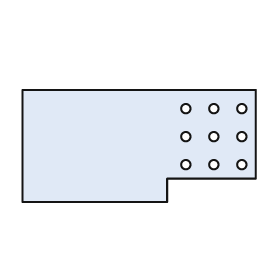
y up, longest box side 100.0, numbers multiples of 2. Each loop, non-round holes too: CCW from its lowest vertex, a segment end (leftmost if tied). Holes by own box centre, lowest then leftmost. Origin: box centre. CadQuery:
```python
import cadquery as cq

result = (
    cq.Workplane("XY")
    .moveTo(-50.0, -24.0)
    .lineTo(12.0, -24.0)
    .lineTo(12.0, -14.0)
    .lineTo(50.0, -14.0)
    .lineTo(50.0, 24.0)
    .lineTo(-50.0, 24.0)
    .close()
    .moveTo(20.0, -8.0)
    .circle(2.0)
    .moveTo(32.0, -8.0)
    .circle(2.0)
    .moveTo(44.0, -8.0)
    .circle(2.0)
    .moveTo(20.0, 4.0)
    .circle(2.0)
    .moveTo(32.0, 4.0)
    .circle(2.0)
    .moveTo(44.0, 4.0)
    .circle(2.0)
    .moveTo(20.0, 16.0)
    .circle(2.0)
    .moveTo(32.0, 16.0)
    .circle(2.0)
    .moveTo(44.0, 16.0)
    .circle(2.0)
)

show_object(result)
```